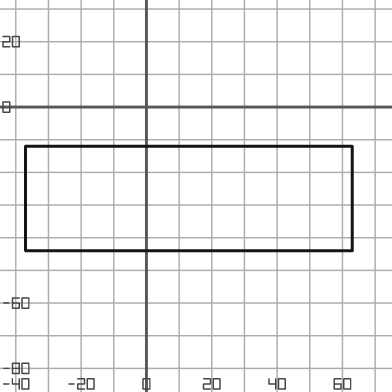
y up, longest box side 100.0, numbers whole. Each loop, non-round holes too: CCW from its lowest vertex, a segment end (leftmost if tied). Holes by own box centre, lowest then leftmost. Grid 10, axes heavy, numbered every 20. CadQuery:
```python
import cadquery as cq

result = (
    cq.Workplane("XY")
    .moveTo(-37.0, -44.0)
    .lineTo(63.0, -44.0)
    .lineTo(63.0, -12.0)
    .lineTo(-37.0, -12.0)
    .close()
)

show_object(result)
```